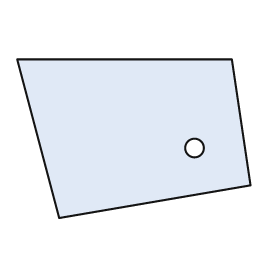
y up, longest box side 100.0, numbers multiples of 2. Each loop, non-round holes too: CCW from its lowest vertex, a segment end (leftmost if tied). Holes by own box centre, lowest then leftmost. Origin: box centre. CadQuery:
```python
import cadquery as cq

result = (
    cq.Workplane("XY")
    .moveTo(-32.0, -34.0)
    .lineTo(50.0, -20.0)
    .lineTo(42.0, 34.0)
    .lineTo(-50.0, 34.0)
    .close()
    .moveTo(26.0, -4.0)
    .circle(4.0)
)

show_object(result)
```